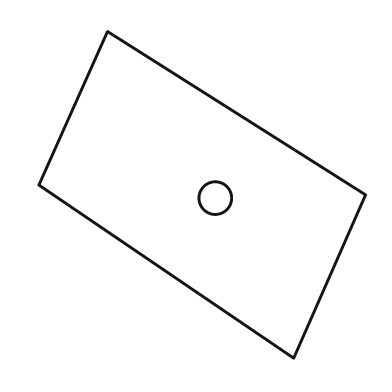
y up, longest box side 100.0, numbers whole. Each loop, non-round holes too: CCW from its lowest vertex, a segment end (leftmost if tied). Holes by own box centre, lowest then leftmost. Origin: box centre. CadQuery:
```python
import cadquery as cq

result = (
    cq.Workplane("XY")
    .moveTo(28.0, -50.0)
    .lineTo(50.0, 0.0)
    .lineTo(-29.0, 50.0)
    .lineTo(-50.0, 3.0)
    .close()
    .moveTo(4.0, -1.0)
    .circle(5.0)
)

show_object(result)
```